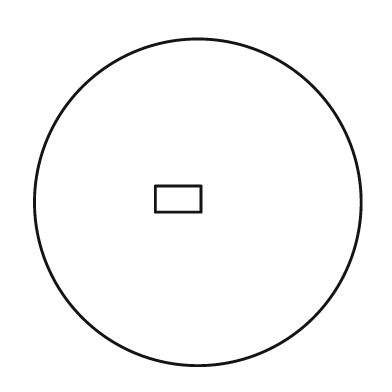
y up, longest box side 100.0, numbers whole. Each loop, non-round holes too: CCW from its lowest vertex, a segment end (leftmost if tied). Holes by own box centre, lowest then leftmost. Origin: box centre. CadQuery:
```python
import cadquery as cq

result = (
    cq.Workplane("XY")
    .moveTo(0.0, 0.0)
    .circle(50.0)
    .moveTo(-13.0, -3.0)
    .lineTo(1.0, -3.0)
    .lineTo(1.0, 5.0)
    .lineTo(-13.0, 5.0)
    .close()
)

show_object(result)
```